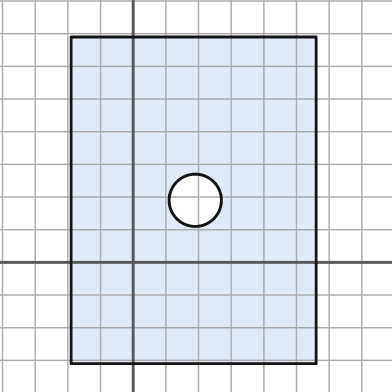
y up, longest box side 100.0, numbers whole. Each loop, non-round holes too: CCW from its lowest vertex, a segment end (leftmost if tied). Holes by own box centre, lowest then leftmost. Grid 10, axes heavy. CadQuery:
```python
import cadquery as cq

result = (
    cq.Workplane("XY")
    .moveTo(-19.0, -31.0)
    .lineTo(56.0, -31.0)
    .lineTo(56.0, 69.0)
    .lineTo(-19.0, 69.0)
    .close()
    .moveTo(19.0, 19.0)
    .circle(8.0)
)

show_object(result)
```